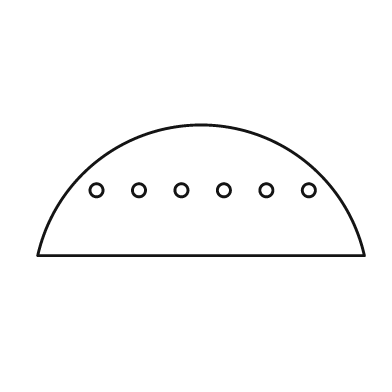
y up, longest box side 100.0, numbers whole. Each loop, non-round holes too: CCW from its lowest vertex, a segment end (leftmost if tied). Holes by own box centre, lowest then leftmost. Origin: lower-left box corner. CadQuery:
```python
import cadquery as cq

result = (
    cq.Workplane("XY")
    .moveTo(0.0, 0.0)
    .lineTo(100.0, 0.0)
    .threePointArc((50.0, 40.0), (0.0, 0.0))
    .close()
    .moveTo(18.0, 20.0)
    .circle(2.0)
    .moveTo(31.0, 20.0)
    .circle(2.0)
    .moveTo(44.0, 20.0)
    .circle(2.0)
    .moveTo(57.0, 20.0)
    .circle(2.0)
    .moveTo(70.0, 20.0)
    .circle(2.0)
    .moveTo(83.0, 20.0)
    .circle(2.0)
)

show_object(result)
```